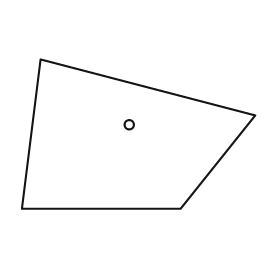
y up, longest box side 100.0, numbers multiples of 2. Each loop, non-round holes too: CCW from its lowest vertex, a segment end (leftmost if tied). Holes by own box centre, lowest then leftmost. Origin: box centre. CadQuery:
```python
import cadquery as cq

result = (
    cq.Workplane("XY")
    .moveTo(-50.0, -32.0)
    .lineTo(18.0, -32.0)
    .lineTo(50.0, 8.0)
    .lineTo(-42.0, 32.0)
    .close()
    .moveTo(-4.0, 4.0)
    .circle(2.0)
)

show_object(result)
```